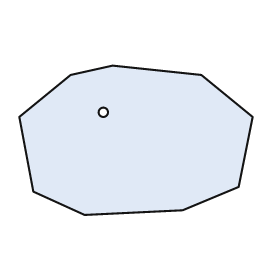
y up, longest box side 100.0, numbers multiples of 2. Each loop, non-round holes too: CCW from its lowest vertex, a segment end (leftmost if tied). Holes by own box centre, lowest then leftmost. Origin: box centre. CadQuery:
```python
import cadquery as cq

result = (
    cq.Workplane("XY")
    .moveTo(-22.0, -32.0)
    .lineTo(20.0, -30.0)
    .lineTo(44.0, -20.0)
    .lineTo(50.0, 10.0)
    .lineTo(28.0, 28.0)
    .lineTo(-10.0, 32.0)
    .lineTo(-28.0, 28.0)
    .lineTo(-50.0, 10.0)
    .lineTo(-44.0, -22.0)
    .close()
    .moveTo(-14.0, 12.0)
    .circle(2.0)
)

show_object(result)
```